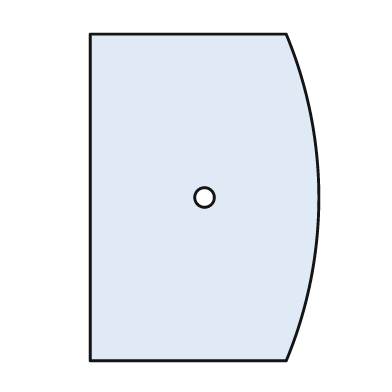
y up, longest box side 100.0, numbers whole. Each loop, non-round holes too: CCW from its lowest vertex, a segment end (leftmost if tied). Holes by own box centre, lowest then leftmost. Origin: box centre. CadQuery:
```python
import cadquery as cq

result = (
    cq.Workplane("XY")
    .moveTo(-35.0, -50.0)
    .lineTo(25.0, -50.0)
    .threePointArc((35.0, 0.0), (25.0, 50.0))
    .lineTo(-35.0, 50.0)
    .close()
    .moveTo(0.0, 0.0)
    .circle(3.0)
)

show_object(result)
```